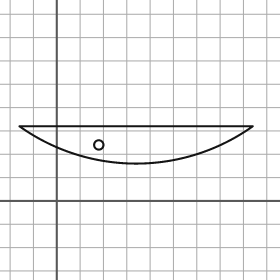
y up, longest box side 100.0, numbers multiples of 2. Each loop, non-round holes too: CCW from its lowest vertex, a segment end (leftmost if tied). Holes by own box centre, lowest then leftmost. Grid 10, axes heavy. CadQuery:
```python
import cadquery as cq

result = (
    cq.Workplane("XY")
    .moveTo(-16.0, 32.0)
    .threePointArc((34.0, 16.0), (84.0, 32.0))
    .close()
    .moveTo(18.0, 24.0)
    .circle(2.0)
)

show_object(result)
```